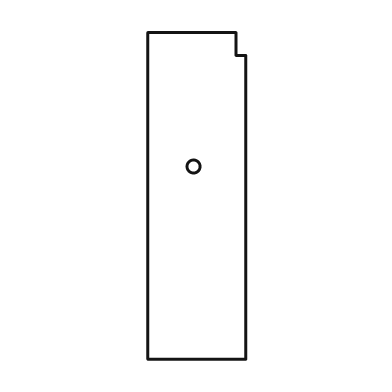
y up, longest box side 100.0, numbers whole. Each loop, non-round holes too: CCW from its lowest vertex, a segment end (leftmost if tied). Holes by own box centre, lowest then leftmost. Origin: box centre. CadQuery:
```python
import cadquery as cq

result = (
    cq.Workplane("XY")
    .moveTo(-15.0, -50.0)
    .lineTo(15.0, -50.0)
    .lineTo(15.0, 43.0)
    .lineTo(12.0, 43.0)
    .lineTo(12.0, 50.0)
    .lineTo(-15.0, 50.0)
    .close()
    .moveTo(-1.0, 9.0)
    .circle(2.0)
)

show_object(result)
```